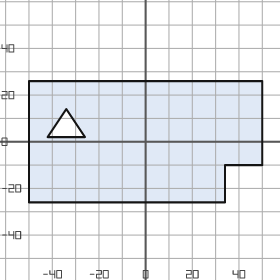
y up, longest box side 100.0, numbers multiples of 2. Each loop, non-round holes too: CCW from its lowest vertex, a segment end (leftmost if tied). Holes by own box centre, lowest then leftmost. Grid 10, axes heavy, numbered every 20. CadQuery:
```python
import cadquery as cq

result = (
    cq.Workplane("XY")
    .moveTo(-50.0, -26.0)
    .lineTo(34.0, -26.0)
    .lineTo(34.0, -10.0)
    .lineTo(50.0, -10.0)
    .lineTo(50.0, 26.0)
    .lineTo(-50.0, 26.0)
    .close()
    .moveTo(-42.0, 2.0)
    .lineTo(-26.0, 2.0)
    .lineTo(-34.0, 14.0)
    .close()
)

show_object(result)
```